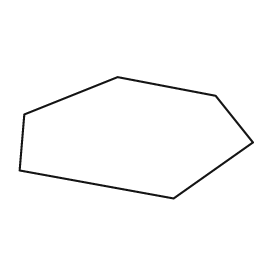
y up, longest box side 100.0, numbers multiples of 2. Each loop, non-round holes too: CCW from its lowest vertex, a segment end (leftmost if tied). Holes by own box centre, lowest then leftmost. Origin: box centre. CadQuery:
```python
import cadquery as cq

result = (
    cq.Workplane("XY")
    .moveTo(16.0, -26.0)
    .lineTo(50.0, -2.0)
    .lineTo(34.0, 18.0)
    .lineTo(-8.0, 26.0)
    .lineTo(-48.0, 10.0)
    .lineTo(-50.0, -14.0)
    .close()
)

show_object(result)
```